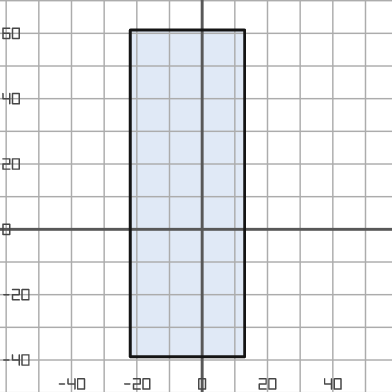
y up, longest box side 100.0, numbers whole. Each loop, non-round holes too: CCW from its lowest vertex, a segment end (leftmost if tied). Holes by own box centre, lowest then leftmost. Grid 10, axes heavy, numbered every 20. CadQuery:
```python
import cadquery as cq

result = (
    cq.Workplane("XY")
    .moveTo(-22.0, -39.0)
    .lineTo(13.0, -39.0)
    .lineTo(13.0, 61.0)
    .lineTo(-22.0, 61.0)
    .close()
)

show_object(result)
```